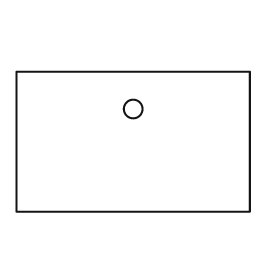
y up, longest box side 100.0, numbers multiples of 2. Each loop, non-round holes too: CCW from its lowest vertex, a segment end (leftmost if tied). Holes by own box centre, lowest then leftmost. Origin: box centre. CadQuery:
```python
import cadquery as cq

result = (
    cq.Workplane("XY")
    .moveTo(-50.0, -30.0)
    .lineTo(50.0, -30.0)
    .lineTo(50.0, 30.0)
    .lineTo(-50.0, 30.0)
    .close()
    .moveTo(0.0, 14.0)
    .circle(4.0)
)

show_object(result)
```